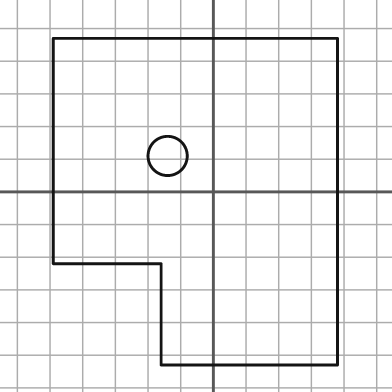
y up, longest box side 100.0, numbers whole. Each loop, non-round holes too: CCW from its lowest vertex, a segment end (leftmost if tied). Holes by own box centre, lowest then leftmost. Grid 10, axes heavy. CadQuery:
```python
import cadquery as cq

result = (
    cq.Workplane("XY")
    .moveTo(-16.0, -53.0)
    .lineTo(38.0, -53.0)
    .lineTo(38.0, 47.0)
    .lineTo(-49.0, 47.0)
    .lineTo(-49.0, -22.0)
    .lineTo(-16.0, -22.0)
    .close()
    .moveTo(-14.0, 11.0)
    .circle(6.0)
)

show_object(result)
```